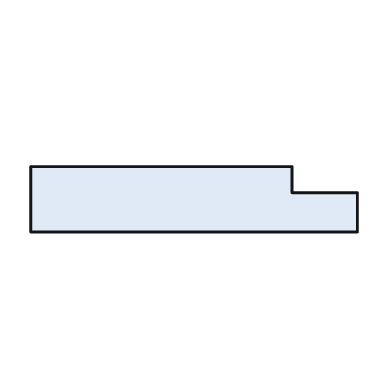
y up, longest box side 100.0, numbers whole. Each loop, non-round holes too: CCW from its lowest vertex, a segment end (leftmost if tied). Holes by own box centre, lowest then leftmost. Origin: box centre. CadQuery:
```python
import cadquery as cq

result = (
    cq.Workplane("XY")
    .moveTo(-50.0, -10.0)
    .lineTo(50.0, -10.0)
    .lineTo(50.0, 2.0)
    .lineTo(30.0, 2.0)
    .lineTo(30.0, 10.0)
    .lineTo(-50.0, 10.0)
    .close()
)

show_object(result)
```